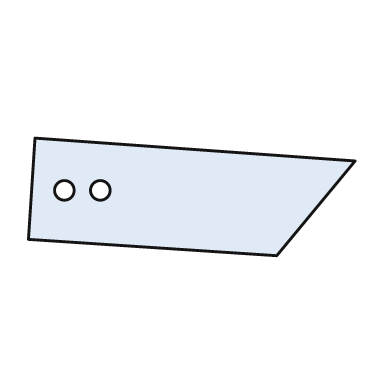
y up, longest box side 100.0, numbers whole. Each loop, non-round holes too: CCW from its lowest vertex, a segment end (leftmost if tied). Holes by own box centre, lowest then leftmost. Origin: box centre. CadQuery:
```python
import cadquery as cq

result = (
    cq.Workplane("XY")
    .moveTo(26.0, -18.0)
    .lineTo(50.0, 11.0)
    .lineTo(-48.0, 18.0)
    .lineTo(-50.0, -13.0)
    .close()
    .moveTo(-39.0, 2.0)
    .circle(3.0)
    .moveTo(-28.0, 2.0)
    .circle(3.0)
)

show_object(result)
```